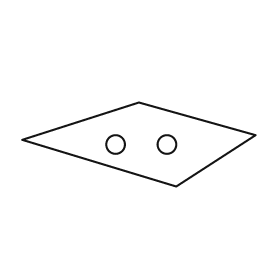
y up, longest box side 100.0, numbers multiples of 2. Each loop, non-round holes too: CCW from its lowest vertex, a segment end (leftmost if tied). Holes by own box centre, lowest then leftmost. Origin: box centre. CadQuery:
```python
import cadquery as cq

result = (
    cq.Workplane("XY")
    .moveTo(16.0, -18.0)
    .lineTo(50.0, 4.0)
    .lineTo(0.0, 18.0)
    .lineTo(-50.0, 2.0)
    .close()
    .moveTo(-10.0, 0.0)
    .circle(4.0)
    .moveTo(12.0, 0.0)
    .circle(4.0)
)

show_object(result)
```